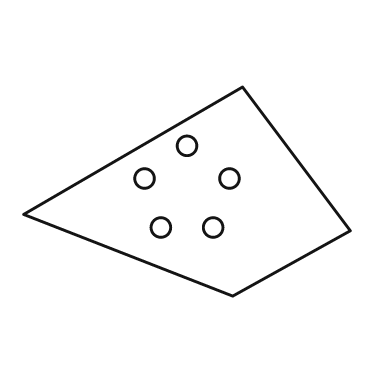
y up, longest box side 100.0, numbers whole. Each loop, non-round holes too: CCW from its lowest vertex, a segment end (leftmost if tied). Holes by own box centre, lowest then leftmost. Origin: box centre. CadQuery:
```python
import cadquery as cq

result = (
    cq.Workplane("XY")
    .moveTo(14.0, -32.0)
    .lineTo(50.0, -12.0)
    .lineTo(17.0, 32.0)
    .lineTo(-50.0, -7.0)
    .close()
    .moveTo(-8.0, -11.0)
    .circle(3.0)
    .moveTo(8.0, -11.0)
    .circle(3.0)
    .moveTo(-13.0, 4.0)
    .circle(3.0)
    .moveTo(13.0, 4.0)
    .circle(3.0)
    .moveTo(0.0, 14.0)
    .circle(3.0)
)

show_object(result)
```